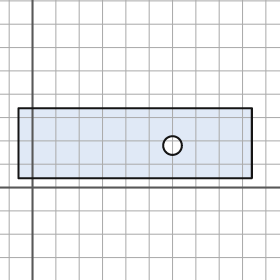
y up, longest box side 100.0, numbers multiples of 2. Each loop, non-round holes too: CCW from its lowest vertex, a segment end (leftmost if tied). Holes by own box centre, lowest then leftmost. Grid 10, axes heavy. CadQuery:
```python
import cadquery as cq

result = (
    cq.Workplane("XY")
    .moveTo(-6.0, 4.0)
    .lineTo(94.0, 4.0)
    .lineTo(94.0, 34.0)
    .lineTo(-6.0, 34.0)
    .close()
    .moveTo(60.0, 18.0)
    .circle(4.0)
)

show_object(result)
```